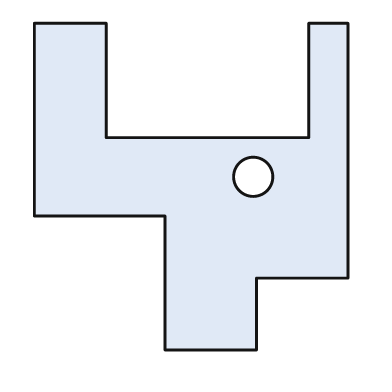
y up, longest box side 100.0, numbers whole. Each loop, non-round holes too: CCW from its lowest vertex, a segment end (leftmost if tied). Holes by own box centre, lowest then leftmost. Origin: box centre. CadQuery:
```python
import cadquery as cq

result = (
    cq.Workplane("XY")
    .moveTo(-8.0, -50.0)
    .lineTo(20.0, -50.0)
    .lineTo(20.0, -28.0)
    .lineTo(48.0, -28.0)
    .lineTo(48.0, 50.0)
    .lineTo(36.0, 50.0)
    .lineTo(36.0, 15.0)
    .lineTo(-26.0, 15.0)
    .lineTo(-26.0, 50.0)
    .lineTo(-48.0, 50.0)
    .lineTo(-48.0, -9.0)
    .lineTo(-8.0, -9.0)
    .close()
    .moveTo(19.0, 3.0)
    .circle(6.0)
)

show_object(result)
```